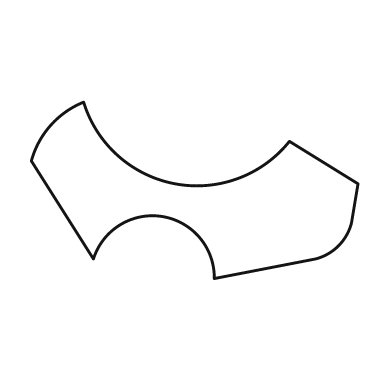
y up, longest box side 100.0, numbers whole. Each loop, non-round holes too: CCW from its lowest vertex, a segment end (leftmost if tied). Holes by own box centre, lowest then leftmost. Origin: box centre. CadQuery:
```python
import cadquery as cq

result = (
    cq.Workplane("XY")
    .moveTo(6.0, -27.0)
    .lineTo(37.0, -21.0)
    .threePointArc((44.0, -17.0), (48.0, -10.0))
    .lineTo(50.0, 2.0)
    .lineTo(29.0, 15.0)
    .threePointArc((-6.0, 2.0), (-34.0, 27.0))
    .threePointArc((-44.0, 20.0), (-50.0, 9.0))
    .lineTo(-31.0, -21.0)
    .threePointArc((-10.0, -8.0), (6.0, -27.0))
    .close()
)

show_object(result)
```